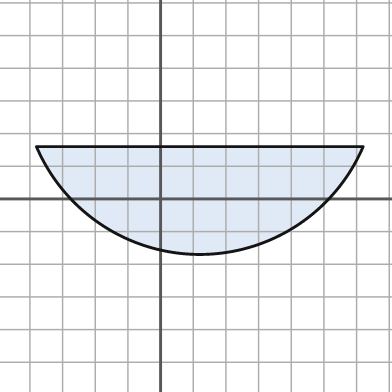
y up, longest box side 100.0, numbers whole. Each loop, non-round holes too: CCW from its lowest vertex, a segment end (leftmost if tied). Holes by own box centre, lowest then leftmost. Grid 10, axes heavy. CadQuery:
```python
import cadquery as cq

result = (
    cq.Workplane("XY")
    .moveTo(-38.0, 16.0)
    .threePointArc((12.0, -17.0), (62.0, 16.0))
    .close()
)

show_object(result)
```